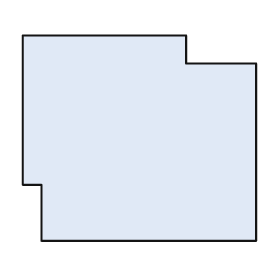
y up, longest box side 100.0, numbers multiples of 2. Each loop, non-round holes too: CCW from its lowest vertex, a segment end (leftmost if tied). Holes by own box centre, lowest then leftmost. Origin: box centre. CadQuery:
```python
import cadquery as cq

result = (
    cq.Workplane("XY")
    .moveTo(-42.0, -44.0)
    .lineTo(50.0, -44.0)
    .lineTo(50.0, 32.0)
    .lineTo(20.0, 32.0)
    .lineTo(20.0, 44.0)
    .lineTo(-50.0, 44.0)
    .lineTo(-50.0, -20.0)
    .lineTo(-42.0, -20.0)
    .close()
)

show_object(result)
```